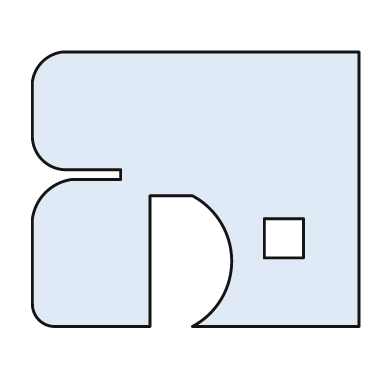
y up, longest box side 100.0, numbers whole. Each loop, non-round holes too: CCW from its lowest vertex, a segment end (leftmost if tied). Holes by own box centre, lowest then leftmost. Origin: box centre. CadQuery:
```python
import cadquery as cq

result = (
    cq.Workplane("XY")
    .moveTo(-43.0, -42.0)
    .lineTo(-14.0, -42.0)
    .lineTo(-14.0, -2.0)
    .lineTo(-1.0, -2.0)
    .threePointArc((11.0, -22.0), (-1.0, -42.0))
    .lineTo(50.0, -42.0)
    .lineTo(50.0, 42.0)
    .lineTo(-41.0, 42.0)
    .threePointArc((-47.0, 39.0), (-50.0, 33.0))
    .lineTo(-50.0, 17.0)
    .threePointArc((-47.0, 9.0), (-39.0, 6.0))
    .lineTo(-23.0, 6.0)
    .lineTo(-23.0, 3.0)
    .lineTo(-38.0, 3.0)
    .threePointArc((-46.0, -1.0), (-50.0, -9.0))
    .lineTo(-50.0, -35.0)
    .threePointArc((-48.0, -40.0), (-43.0, -42.0))
    .close()
    .moveTo(21.0, -21.0)
    .lineTo(33.0, -21.0)
    .lineTo(33.0, -9.0)
    .lineTo(21.0, -9.0)
    .close()
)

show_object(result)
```